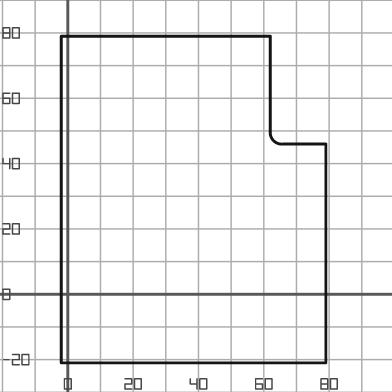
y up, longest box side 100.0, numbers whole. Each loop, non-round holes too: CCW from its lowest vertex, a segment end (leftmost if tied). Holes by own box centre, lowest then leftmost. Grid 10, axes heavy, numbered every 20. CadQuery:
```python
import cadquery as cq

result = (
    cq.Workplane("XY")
    .moveTo(-2.0, -21.0)
    .lineTo(79.0, -21.0)
    .lineTo(79.0, 46.0)
    .lineTo(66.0, 46.0)
    .threePointArc((63.0, 47.0), (62.0, 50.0))
    .lineTo(62.0, 79.0)
    .lineTo(-2.0, 79.0)
    .close()
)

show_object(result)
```